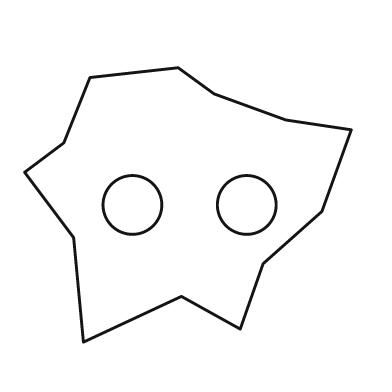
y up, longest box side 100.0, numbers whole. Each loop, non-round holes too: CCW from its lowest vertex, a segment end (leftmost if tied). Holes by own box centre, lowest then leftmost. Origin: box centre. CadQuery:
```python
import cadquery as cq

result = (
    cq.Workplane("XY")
    .moveTo(-32.0, -42.0)
    .lineTo(-2.0, -28.0)
    .lineTo(16.0, -38.0)
    .lineTo(23.0, -18.0)
    .lineTo(41.0, -2.0)
    .lineTo(50.0, 23.0)
    .lineTo(30.0, 26.0)
    .lineTo(8.0, 34.0)
    .lineTo(-3.0, 42.0)
    .lineTo(-30.0, 39.0)
    .lineTo(-38.0, 19.0)
    .lineTo(-50.0, 10.0)
    .lineTo(-35.0, -10.0)
    .close()
    .moveTo(-17.0, 0.0)
    .circle(9.0)
    .moveTo(18.0, 0.0)
    .circle(9.0)
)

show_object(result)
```